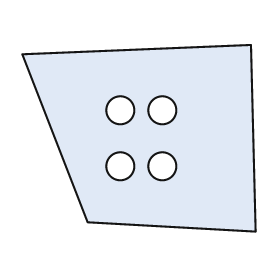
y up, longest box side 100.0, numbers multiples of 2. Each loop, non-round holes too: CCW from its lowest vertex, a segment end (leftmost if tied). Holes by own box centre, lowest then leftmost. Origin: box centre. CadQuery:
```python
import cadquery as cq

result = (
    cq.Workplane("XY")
    .moveTo(50.0, -40.0)
    .lineTo(48.0, 40.0)
    .lineTo(-50.0, 36.0)
    .lineTo(-22.0, -36.0)
    .close()
    .moveTo(-8.0, -12.0)
    .circle(6.0)
    .moveTo(10.0, -12.0)
    .circle(6.0)
    .moveTo(-8.0, 12.0)
    .circle(6.0)
    .moveTo(10.0, 12.0)
    .circle(6.0)
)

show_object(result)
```